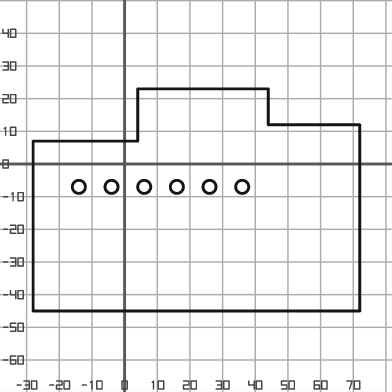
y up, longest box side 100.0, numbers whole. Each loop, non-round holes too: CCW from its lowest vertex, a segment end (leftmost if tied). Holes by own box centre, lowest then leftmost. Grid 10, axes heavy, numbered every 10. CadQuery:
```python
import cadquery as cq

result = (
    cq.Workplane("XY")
    .moveTo(-28.0, -45.0)
    .lineTo(72.0, -45.0)
    .lineTo(72.0, 12.0)
    .lineTo(44.0, 12.0)
    .lineTo(44.0, 23.0)
    .lineTo(4.0, 23.0)
    .lineTo(4.0, 7.0)
    .lineTo(-28.0, 7.0)
    .close()
    .moveTo(-14.0, -7.0)
    .circle(2.0)
    .moveTo(-4.0, -7.0)
    .circle(2.0)
    .moveTo(6.0, -7.0)
    .circle(2.0)
    .moveTo(16.0, -7.0)
    .circle(2.0)
    .moveTo(26.0, -7.0)
    .circle(2.0)
    .moveTo(36.0, -7.0)
    .circle(2.0)
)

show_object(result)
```